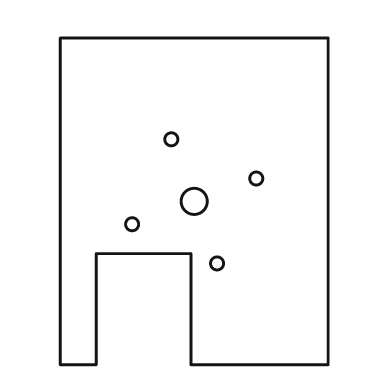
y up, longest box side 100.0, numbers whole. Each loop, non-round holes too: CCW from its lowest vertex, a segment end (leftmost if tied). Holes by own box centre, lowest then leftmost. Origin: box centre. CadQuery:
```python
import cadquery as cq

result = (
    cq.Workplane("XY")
    .moveTo(-41.0, -50.0)
    .lineTo(-30.0, -50.0)
    .lineTo(-30.0, -16.0)
    .lineTo(-1.0, -16.0)
    .lineTo(-1.0, -50.0)
    .lineTo(41.0, -50.0)
    .lineTo(41.0, 50.0)
    .lineTo(-41.0, 50.0)
    .close()
    .moveTo(7.0, -19.0)
    .circle(2.0)
    .moveTo(-19.0, -7.0)
    .circle(2.0)
    .moveTo(0.0, 0.0)
    .circle(4.0)
    .moveTo(19.0, 7.0)
    .circle(2.0)
    .moveTo(-7.0, 19.0)
    .circle(2.0)
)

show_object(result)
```